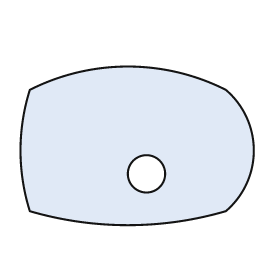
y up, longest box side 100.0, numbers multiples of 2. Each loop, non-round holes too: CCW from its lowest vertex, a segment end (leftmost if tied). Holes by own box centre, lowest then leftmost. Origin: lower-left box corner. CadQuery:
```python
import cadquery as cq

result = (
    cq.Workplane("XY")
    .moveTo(4.0, 6.0)
    .threePointArc((46.0, 0.0), (88.0, 6.0))
    .threePointArc((100.0, 32.0), (88.0, 58.0))
    .threePointArc((46.0, 68.0), (4.0, 58.0))
    .threePointArc((0.0, 32.0), (4.0, 6.0))
    .close()
    .moveTo(54.0, 22.0)
    .circle(8.0)
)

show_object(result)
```